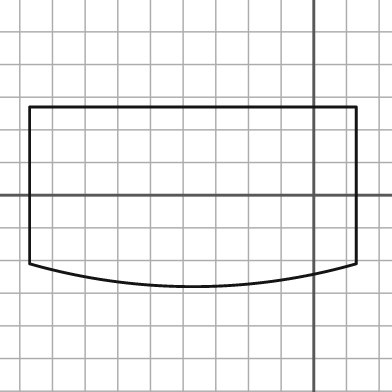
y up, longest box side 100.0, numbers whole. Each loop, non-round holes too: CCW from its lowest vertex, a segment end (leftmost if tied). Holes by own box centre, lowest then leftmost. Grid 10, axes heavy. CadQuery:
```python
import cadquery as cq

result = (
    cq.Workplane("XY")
    .moveTo(-87.0, -21.0)
    .threePointArc((-37.0, -28.0), (13.0, -21.0))
    .lineTo(13.0, 27.0)
    .lineTo(-87.0, 27.0)
    .close()
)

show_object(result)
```